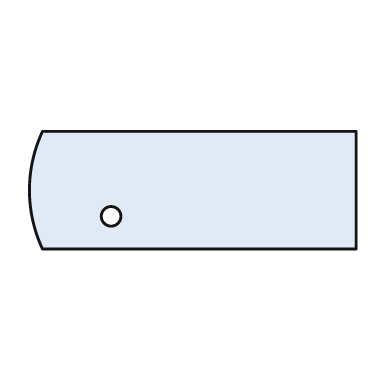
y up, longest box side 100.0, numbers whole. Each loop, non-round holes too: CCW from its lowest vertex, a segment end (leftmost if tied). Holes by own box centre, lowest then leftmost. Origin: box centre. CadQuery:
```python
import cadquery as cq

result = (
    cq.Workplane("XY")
    .moveTo(-46.0, -18.0)
    .lineTo(50.0, -18.0)
    .lineTo(50.0, 18.0)
    .lineTo(-46.0, 18.0)
    .threePointArc((-50.0, 0.0), (-46.0, -18.0))
    .close()
    .moveTo(-25.0, -8.0)
    .circle(3.0)
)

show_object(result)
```